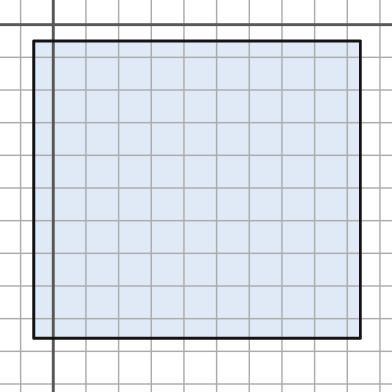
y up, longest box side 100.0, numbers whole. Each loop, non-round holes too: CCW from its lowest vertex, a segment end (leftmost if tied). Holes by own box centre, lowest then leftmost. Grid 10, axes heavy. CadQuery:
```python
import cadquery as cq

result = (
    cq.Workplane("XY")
    .moveTo(-6.0, -96.0)
    .lineTo(94.0, -96.0)
    .lineTo(94.0, -5.0)
    .lineTo(-6.0, -5.0)
    .close()
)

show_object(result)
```